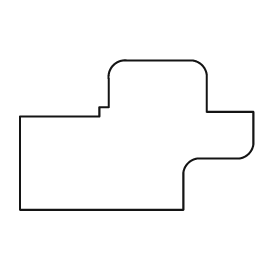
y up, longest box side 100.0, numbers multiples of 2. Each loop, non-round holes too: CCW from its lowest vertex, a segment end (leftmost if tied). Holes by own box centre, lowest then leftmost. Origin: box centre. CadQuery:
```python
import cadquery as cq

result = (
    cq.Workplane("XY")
    .moveTo(-50.0, -32.0)
    .lineTo(20.0, -32.0)
    .lineTo(20.0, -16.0)
    .threePointArc((22.0, -12.0), (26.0, -10.0))
    .lineTo(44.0, -10.0)
    .threePointArc((48.0, -8.0), (50.0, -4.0))
    .lineTo(50.0, 10.0)
    .lineTo(30.0, 10.0)
    .lineTo(30.0, 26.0)
    .threePointArc((28.0, 30.0), (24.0, 32.0))
    .lineTo(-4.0, 32.0)
    .threePointArc((-10.0, 30.0), (-12.0, 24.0))
    .lineTo(-12.0, 12.0)
    .lineTo(-16.0, 12.0)
    .lineTo(-16.0, 8.0)
    .lineTo(-50.0, 8.0)
    .close()
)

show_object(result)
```